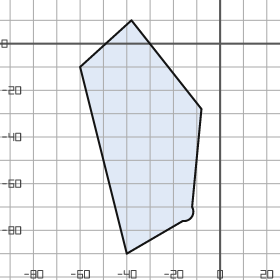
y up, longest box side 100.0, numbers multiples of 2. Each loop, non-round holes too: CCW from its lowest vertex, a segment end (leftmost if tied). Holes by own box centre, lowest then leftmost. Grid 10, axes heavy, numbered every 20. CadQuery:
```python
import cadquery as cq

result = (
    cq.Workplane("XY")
    .moveTo(-40.0, -90.0)
    .lineTo(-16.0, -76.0)
    .threePointArc((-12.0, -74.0), (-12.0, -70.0))
    .lineTo(-8.0, -28.0)
    .lineTo(-38.0, 10.0)
    .lineTo(-60.0, -10.0)
    .close()
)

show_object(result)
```